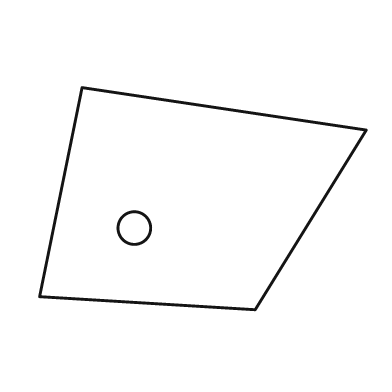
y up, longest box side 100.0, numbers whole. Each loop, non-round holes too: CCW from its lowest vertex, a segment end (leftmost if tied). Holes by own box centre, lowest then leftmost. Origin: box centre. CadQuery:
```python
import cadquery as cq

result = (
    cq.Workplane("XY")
    .moveTo(16.0, -34.0)
    .lineTo(50.0, 21.0)
    .lineTo(-37.0, 34.0)
    .lineTo(-50.0, -30.0)
    .close()
    .moveTo(-21.0, -9.0)
    .circle(5.0)
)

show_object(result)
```